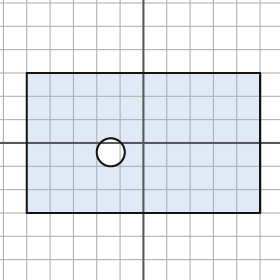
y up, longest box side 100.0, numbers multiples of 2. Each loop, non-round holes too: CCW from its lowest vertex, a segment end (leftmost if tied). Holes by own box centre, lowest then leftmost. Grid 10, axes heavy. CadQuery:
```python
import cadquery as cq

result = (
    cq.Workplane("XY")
    .moveTo(-50.0, -30.0)
    .lineTo(50.0, -30.0)
    .lineTo(50.0, 30.0)
    .lineTo(-50.0, 30.0)
    .close()
    .moveTo(-14.0, -4.0)
    .circle(6.0)
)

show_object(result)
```